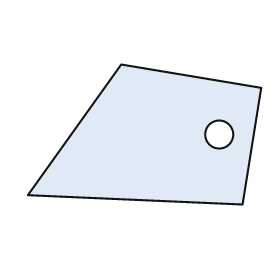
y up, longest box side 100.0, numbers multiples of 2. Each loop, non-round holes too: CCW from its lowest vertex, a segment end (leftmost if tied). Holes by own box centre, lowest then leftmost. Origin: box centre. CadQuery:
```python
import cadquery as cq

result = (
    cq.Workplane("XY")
    .moveTo(42.0, -30.0)
    .lineTo(50.0, 20.0)
    .lineTo(-10.0, 30.0)
    .lineTo(-50.0, -26.0)
    .close()
    .moveTo(32.0, 0.0)
    .circle(6.0)
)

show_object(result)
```